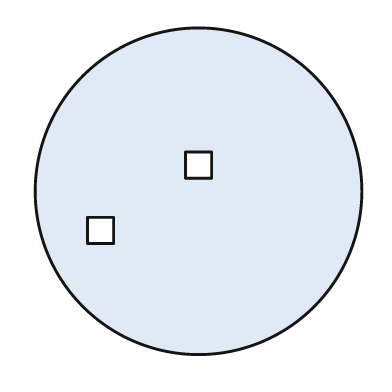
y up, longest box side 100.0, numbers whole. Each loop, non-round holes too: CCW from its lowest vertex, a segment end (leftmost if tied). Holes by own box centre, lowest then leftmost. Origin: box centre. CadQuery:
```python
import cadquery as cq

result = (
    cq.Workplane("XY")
    .moveTo(0.0, 0.0)
    .circle(50.0)
    .moveTo(-34.0, -16.0)
    .lineTo(-26.0, -16.0)
    .lineTo(-26.0, -8.0)
    .lineTo(-34.0, -8.0)
    .close()
    .moveTo(-4.0, 4.0)
    .lineTo(4.0, 4.0)
    .lineTo(4.0, 12.0)
    .lineTo(-4.0, 12.0)
    .close()
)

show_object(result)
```